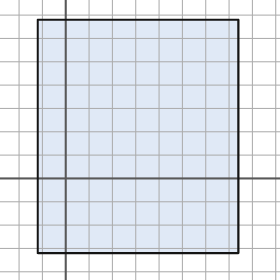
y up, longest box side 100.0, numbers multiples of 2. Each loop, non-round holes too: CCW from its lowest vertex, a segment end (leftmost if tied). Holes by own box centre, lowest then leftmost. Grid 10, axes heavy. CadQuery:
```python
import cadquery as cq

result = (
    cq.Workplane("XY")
    .moveTo(-12.0, -32.0)
    .lineTo(74.0, -32.0)
    .lineTo(74.0, 68.0)
    .lineTo(-12.0, 68.0)
    .close()
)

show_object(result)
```